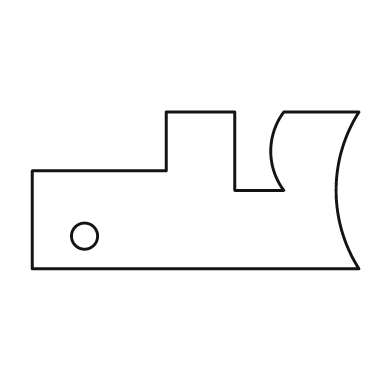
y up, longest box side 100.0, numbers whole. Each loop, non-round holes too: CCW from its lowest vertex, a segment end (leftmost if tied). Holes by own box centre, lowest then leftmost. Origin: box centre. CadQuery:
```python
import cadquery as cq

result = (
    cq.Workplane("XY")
    .moveTo(-50.0, -24.0)
    .lineTo(50.0, -24.0)
    .threePointArc((43.0, 0.0), (50.0, 24.0))
    .lineTo(27.0, 24.0)
    .threePointArc((23.0, 12.0), (27.0, 0.0))
    .lineTo(12.0, 0.0)
    .lineTo(12.0, 24.0)
    .lineTo(-9.0, 24.0)
    .lineTo(-9.0, 6.0)
    .lineTo(-50.0, 6.0)
    .close()
    .moveTo(-34.0, -14.0)
    .circle(4.0)
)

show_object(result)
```